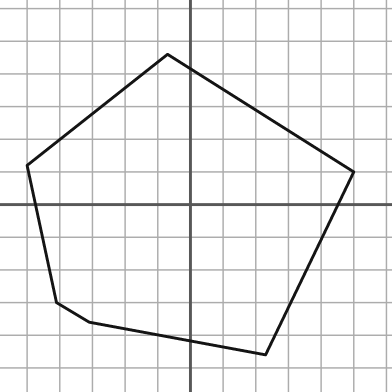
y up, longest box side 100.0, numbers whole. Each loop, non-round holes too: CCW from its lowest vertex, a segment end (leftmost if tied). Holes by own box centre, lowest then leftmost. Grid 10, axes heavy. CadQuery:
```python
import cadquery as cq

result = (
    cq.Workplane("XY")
    .moveTo(23.0, -46.0)
    .lineTo(50.0, 10.0)
    .lineTo(-7.0, 46.0)
    .lineTo(-50.0, 12.0)
    .lineTo(-41.0, -30.0)
    .lineTo(-31.0, -36.0)
    .close()
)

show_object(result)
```